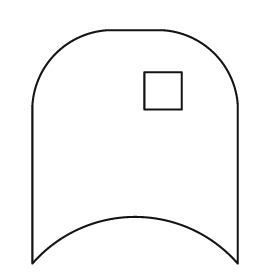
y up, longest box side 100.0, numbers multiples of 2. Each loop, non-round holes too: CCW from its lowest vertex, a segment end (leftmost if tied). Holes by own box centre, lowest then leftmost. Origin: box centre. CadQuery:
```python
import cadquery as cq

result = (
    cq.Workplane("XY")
    .moveTo(-44.0, -50.0)
    .threePointArc((0.0, -30.0), (44.0, -50.0))
    .lineTo(44.0, 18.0)
    .threePointArc((34.0, 40.0), (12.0, 50.0))
    .lineTo(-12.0, 50.0)
    .threePointArc((-34.0, 40.0), (-44.0, 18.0))
    .close()
    .moveTo(4.0, 16.0)
    .lineTo(20.0, 16.0)
    .lineTo(20.0, 32.0)
    .lineTo(4.0, 32.0)
    .close()
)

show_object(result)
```